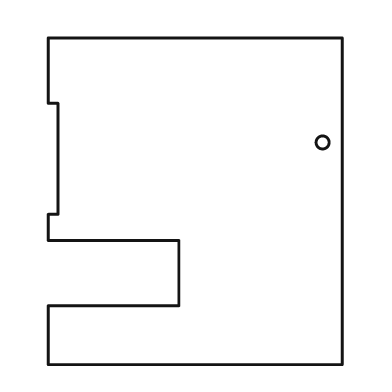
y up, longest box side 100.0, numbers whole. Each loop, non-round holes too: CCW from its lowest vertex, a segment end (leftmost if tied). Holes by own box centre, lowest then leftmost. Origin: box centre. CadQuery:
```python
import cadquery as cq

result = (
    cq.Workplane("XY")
    .moveTo(-45.0, -50.0)
    .lineTo(45.0, -50.0)
    .lineTo(45.0, 50.0)
    .lineTo(-45.0, 50.0)
    .lineTo(-45.0, 30.0)
    .lineTo(-42.0, 30.0)
    .lineTo(-42.0, -4.0)
    .lineTo(-45.0, -4.0)
    .lineTo(-45.0, -12.0)
    .lineTo(-5.0, -12.0)
    .lineTo(-5.0, -32.0)
    .lineTo(-45.0, -32.0)
    .close()
    .moveTo(39.0, 18.0)
    .circle(2.0)
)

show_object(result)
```